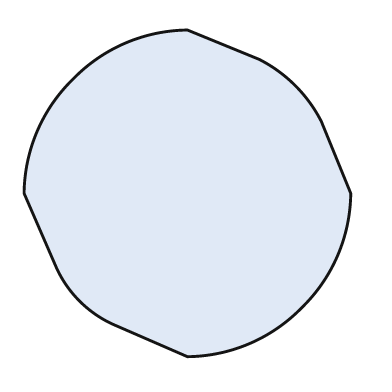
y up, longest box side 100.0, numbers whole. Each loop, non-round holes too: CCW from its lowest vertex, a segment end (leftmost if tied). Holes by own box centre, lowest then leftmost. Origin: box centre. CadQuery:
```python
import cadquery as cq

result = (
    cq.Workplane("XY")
    .moveTo(0.0, -50.0)
    .threePointArc((19.0, -46.0), (35.0, -35.0))
    .threePointArc((46.0, -19.0), (50.0, 0.0))
    .lineTo(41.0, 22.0)
    .threePointArc((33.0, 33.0), (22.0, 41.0))
    .lineTo(0.0, 50.0)
    .threePointArc((-19.0, 46.0), (-35.0, 35.0))
    .threePointArc((-46.0, 19.0), (-50.0, 0.0))
    .lineTo(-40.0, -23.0)
    .threePointArc((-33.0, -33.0), (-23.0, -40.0))
    .close()
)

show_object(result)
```